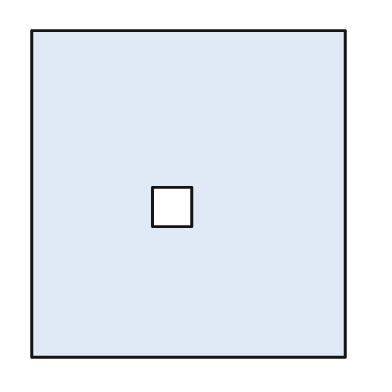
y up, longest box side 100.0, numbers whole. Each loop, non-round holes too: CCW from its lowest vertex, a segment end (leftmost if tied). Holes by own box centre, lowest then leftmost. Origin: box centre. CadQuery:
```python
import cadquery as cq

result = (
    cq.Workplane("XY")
    .moveTo(-48.0, -50.0)
    .lineTo(48.0, -50.0)
    .lineTo(48.0, 50.0)
    .lineTo(-48.0, 50.0)
    .close()
    .moveTo(-11.0, -10.0)
    .lineTo(1.0, -10.0)
    .lineTo(1.0, 2.0)
    .lineTo(-11.0, 2.0)
    .close()
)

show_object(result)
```